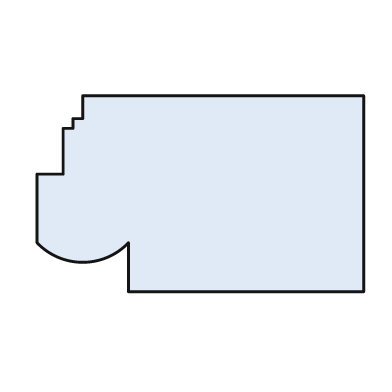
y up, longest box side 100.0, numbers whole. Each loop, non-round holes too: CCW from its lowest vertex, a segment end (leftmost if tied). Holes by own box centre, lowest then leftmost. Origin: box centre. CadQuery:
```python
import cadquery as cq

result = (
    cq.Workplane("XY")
    .moveTo(-22.0, -30.0)
    .lineTo(50.0, -30.0)
    .lineTo(50.0, 30.0)
    .lineTo(-36.0, 30.0)
    .lineTo(-36.0, 23.0)
    .lineTo(-39.0, 23.0)
    .lineTo(-39.0, 20.0)
    .lineTo(-42.0, 20.0)
    .lineTo(-42.0, 6.0)
    .lineTo(-50.0, 6.0)
    .lineTo(-50.0, -15.0)
    .threePointArc((-36.0, -21.0), (-22.0, -15.0))
    .close()
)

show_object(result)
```